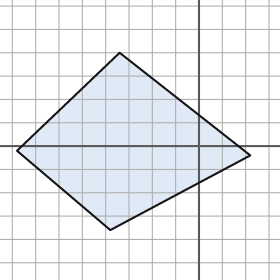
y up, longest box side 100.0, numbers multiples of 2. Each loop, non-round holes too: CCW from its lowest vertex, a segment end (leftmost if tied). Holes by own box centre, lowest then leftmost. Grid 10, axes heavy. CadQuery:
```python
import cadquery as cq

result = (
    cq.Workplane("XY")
    .moveTo(-38.0, -36.0)
    .lineTo(22.0, -4.0)
    .lineTo(-34.0, 40.0)
    .lineTo(-78.0, -2.0)
    .close()
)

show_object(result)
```